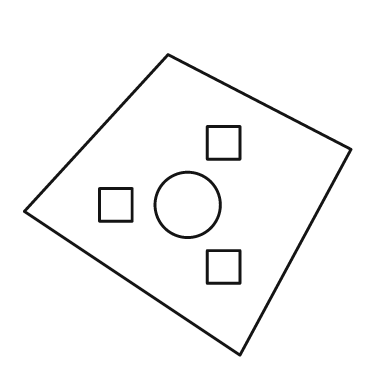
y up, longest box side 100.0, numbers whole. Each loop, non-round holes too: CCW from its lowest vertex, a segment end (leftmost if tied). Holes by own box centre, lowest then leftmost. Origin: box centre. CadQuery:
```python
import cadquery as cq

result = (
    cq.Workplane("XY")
    .moveTo(16.0, -46.0)
    .lineTo(50.0, 17.0)
    .lineTo(-6.0, 46.0)
    .lineTo(-50.0, -2.0)
    .close()
    .moveTo(6.0, -24.0)
    .lineTo(16.0, -24.0)
    .lineTo(16.0, -14.0)
    .lineTo(6.0, -14.0)
    .close()
    .moveTo(-27.0, -5.0)
    .lineTo(-17.0, -5.0)
    .lineTo(-17.0, 5.0)
    .lineTo(-27.0, 5.0)
    .close()
    .moveTo(0.0, 0.0)
    .circle(10.0)
    .moveTo(6.0, 14.0)
    .lineTo(16.0, 14.0)
    .lineTo(16.0, 24.0)
    .lineTo(6.0, 24.0)
    .close()
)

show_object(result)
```